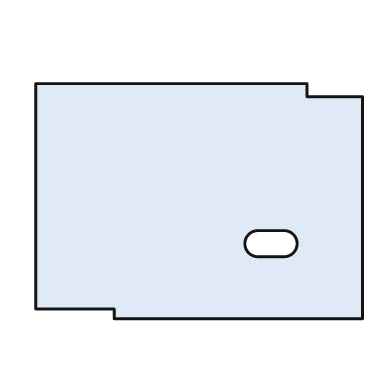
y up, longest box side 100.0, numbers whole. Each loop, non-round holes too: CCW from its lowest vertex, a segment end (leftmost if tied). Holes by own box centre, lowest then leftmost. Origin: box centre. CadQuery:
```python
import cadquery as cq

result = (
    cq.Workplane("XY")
    .moveTo(-26.0, -36.0)
    .lineTo(50.0, -36.0)
    .lineTo(50.0, 32.0)
    .lineTo(33.0, 32.0)
    .lineTo(33.0, 36.0)
    .lineTo(-50.0, 36.0)
    .lineTo(-50.0, -33.0)
    .lineTo(-26.0, -33.0)
    .close()
    .moveTo(18.0, -17.0)
    .lineTo(26.0, -17.0)
    .threePointArc((30.0, -13.0), (26.0, -9.0))
    .lineTo(18.0, -9.0)
    .threePointArc((14.0, -13.0), (18.0, -17.0))
    .close()
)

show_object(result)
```